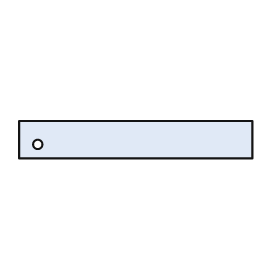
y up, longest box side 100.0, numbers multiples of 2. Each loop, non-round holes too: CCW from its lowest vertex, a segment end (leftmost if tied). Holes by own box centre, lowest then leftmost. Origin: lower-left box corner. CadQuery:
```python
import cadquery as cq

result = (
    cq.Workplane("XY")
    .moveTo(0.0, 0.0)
    .lineTo(100.0, 0.0)
    .lineTo(100.0, 16.0)
    .lineTo(0.0, 16.0)
    .close()
    .moveTo(8.0, 6.0)
    .circle(2.0)
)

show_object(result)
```